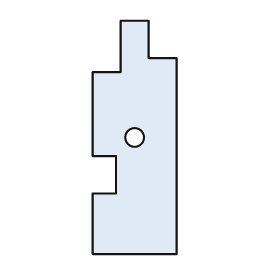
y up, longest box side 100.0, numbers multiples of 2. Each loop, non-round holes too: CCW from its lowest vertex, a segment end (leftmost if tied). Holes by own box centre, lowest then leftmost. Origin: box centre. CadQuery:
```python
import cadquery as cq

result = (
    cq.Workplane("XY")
    .moveTo(-18.0, -50.0)
    .lineTo(18.0, -50.0)
    .lineTo(18.0, 34.0)
    .lineTo(6.0, 34.0)
    .lineTo(6.0, 50.0)
    .lineTo(-6.0, 50.0)
    .lineTo(-6.0, 28.0)
    .lineTo(-18.0, 28.0)
    .lineTo(-18.0, -8.0)
    .lineTo(-8.0, -8.0)
    .lineTo(-8.0, -24.0)
    .lineTo(-18.0, -24.0)
    .close()
    .moveTo(0.0, 0.0)
    .circle(4.0)
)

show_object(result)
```